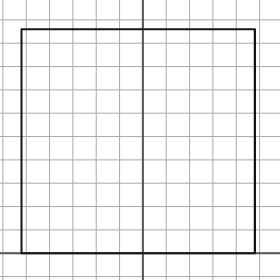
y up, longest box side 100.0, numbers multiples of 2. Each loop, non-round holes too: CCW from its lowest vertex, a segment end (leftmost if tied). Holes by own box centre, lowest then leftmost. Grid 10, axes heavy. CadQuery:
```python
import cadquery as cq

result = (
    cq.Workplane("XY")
    .moveTo(-52.0, 0.0)
    .lineTo(48.0, 0.0)
    .lineTo(48.0, 96.0)
    .lineTo(-52.0, 96.0)
    .close()
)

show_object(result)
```